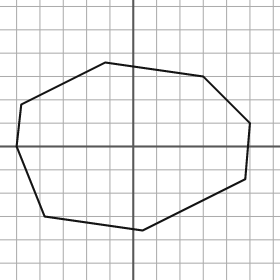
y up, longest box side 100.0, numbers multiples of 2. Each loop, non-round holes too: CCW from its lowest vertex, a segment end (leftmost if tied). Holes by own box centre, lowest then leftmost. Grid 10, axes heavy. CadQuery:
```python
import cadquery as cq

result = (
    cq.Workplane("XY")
    .moveTo(4.0, -36.0)
    .lineTo(48.0, -14.0)
    .lineTo(50.0, 10.0)
    .lineTo(30.0, 30.0)
    .lineTo(-12.0, 36.0)
    .lineTo(-48.0, 18.0)
    .lineTo(-50.0, 0.0)
    .lineTo(-38.0, -30.0)
    .close()
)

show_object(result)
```